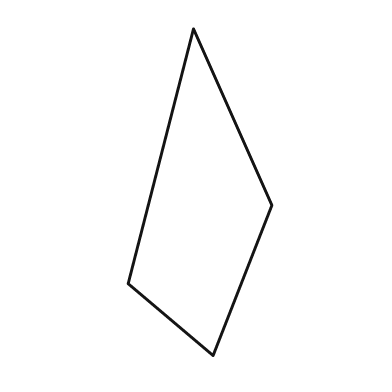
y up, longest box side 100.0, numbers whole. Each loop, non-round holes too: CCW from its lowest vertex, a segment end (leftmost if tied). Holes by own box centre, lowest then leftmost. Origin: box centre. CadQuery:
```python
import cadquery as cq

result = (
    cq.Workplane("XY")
    .moveTo(4.0, -50.0)
    .lineTo(22.0, -4.0)
    .lineTo(-2.0, 50.0)
    .lineTo(-22.0, -28.0)
    .close()
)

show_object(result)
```